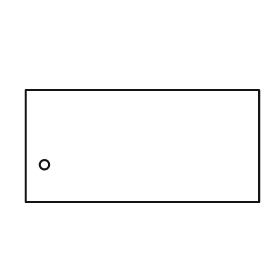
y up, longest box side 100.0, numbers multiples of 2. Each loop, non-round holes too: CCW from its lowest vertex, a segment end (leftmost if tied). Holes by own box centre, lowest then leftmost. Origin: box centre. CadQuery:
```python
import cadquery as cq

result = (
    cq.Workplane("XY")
    .moveTo(-50.0, -24.0)
    .lineTo(50.0, -24.0)
    .lineTo(50.0, 24.0)
    .lineTo(-50.0, 24.0)
    .close()
    .moveTo(-42.0, -8.0)
    .circle(2.0)
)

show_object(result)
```